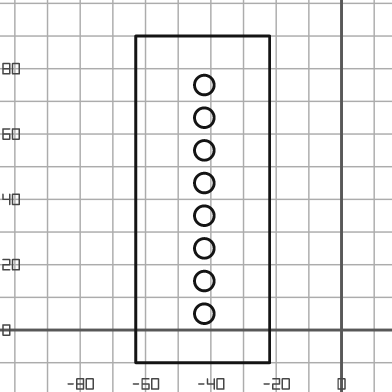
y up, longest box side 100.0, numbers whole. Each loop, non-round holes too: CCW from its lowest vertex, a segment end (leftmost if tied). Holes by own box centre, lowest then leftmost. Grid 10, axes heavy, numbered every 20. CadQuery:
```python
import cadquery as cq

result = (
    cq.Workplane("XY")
    .moveTo(-63.0, -10.0)
    .lineTo(-22.0, -10.0)
    .lineTo(-22.0, 90.0)
    .lineTo(-63.0, 90.0)
    .close()
    .moveTo(-42.0, 5.0)
    .circle(3.0)
    .moveTo(-42.0, 15.0)
    .circle(3.0)
    .moveTo(-42.0, 25.0)
    .circle(3.0)
    .moveTo(-42.0, 35.0)
    .circle(3.0)
    .moveTo(-42.0, 45.0)
    .circle(3.0)
    .moveTo(-42.0, 55.0)
    .circle(3.0)
    .moveTo(-42.0, 65.0)
    .circle(3.0)
    .moveTo(-42.0, 75.0)
    .circle(3.0)
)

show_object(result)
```